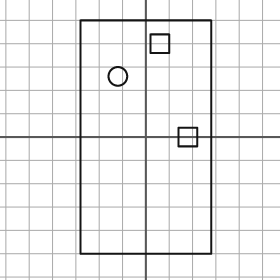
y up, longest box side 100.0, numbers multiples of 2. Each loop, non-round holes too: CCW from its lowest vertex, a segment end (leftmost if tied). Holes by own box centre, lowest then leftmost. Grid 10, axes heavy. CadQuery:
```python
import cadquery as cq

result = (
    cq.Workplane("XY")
    .moveTo(-28.0, -50.0)
    .lineTo(28.0, -50.0)
    .lineTo(28.0, 50.0)
    .lineTo(-28.0, 50.0)
    .close()
    .moveTo(14.0, -4.0)
    .lineTo(22.0, -4.0)
    .lineTo(22.0, 4.0)
    .lineTo(14.0, 4.0)
    .close()
    .moveTo(-12.0, 26.0)
    .circle(4.0)
    .moveTo(2.0, 36.0)
    .lineTo(10.0, 36.0)
    .lineTo(10.0, 44.0)
    .lineTo(2.0, 44.0)
    .close()
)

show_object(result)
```